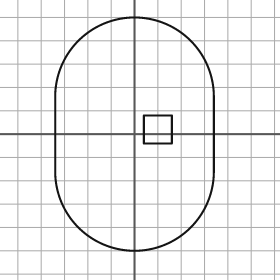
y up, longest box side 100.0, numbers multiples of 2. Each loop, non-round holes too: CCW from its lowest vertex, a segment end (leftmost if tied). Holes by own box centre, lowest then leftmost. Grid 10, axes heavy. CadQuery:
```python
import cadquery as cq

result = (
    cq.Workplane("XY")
    .moveTo(-34.0, -16.0)
    .threePointArc((0.0, -50.0), (34.0, -16.0))
    .lineTo(34.0, 16.0)
    .threePointArc((0.0, 50.0), (-34.0, 16.0))
    .close()
    .moveTo(4.0, -4.0)
    .lineTo(16.0, -4.0)
    .lineTo(16.0, 8.0)
    .lineTo(4.0, 8.0)
    .close()
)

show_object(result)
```